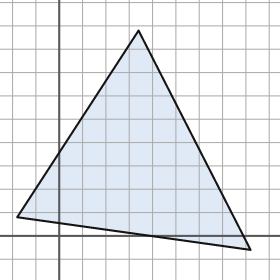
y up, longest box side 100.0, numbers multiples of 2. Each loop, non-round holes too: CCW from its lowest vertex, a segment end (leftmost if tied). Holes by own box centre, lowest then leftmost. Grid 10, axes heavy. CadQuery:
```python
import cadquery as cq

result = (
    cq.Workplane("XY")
    .moveTo(82.0, -6.0)
    .lineTo(34.0, 88.0)
    .lineTo(-18.0, 8.0)
    .close()
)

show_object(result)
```